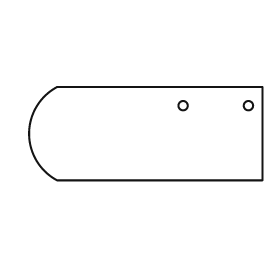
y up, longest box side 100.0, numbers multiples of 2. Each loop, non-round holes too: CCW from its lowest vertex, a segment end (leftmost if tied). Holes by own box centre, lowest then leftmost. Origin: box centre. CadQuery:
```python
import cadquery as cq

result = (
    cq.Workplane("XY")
    .moveTo(-38.0, -20.0)
    .lineTo(50.0, -20.0)
    .lineTo(50.0, 20.0)
    .lineTo(-38.0, 20.0)
    .threePointArc((-50.0, 0.0), (-38.0, -20.0))
    .close()
    .moveTo(16.0, 12.0)
    .circle(2.0)
    .moveTo(44.0, 12.0)
    .circle(2.0)
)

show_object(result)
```